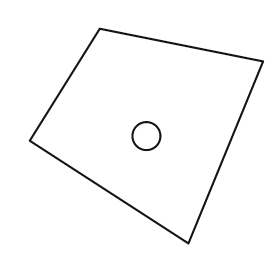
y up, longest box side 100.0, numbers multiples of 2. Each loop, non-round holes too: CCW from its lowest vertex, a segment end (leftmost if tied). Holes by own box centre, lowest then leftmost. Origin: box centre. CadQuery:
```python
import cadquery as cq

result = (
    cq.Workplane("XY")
    .moveTo(18.0, -46.0)
    .lineTo(50.0, 32.0)
    .lineTo(-20.0, 46.0)
    .lineTo(-50.0, -2.0)
    .close()
    .moveTo(0.0, 0.0)
    .circle(6.0)
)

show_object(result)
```